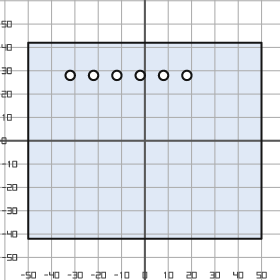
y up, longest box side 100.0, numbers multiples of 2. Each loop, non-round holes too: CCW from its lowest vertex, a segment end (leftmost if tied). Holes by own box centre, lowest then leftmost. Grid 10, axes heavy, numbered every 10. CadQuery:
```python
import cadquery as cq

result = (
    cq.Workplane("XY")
    .moveTo(-50.0, -42.0)
    .lineTo(50.0, -42.0)
    .lineTo(50.0, 42.0)
    .lineTo(-50.0, 42.0)
    .close()
    .moveTo(-32.0, 28.0)
    .circle(2.0)
    .moveTo(-22.0, 28.0)
    .circle(2.0)
    .moveTo(-12.0, 28.0)
    .circle(2.0)
    .moveTo(-2.0, 28.0)
    .circle(2.0)
    .moveTo(8.0, 28.0)
    .circle(2.0)
    .moveTo(18.0, 28.0)
    .circle(2.0)
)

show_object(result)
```